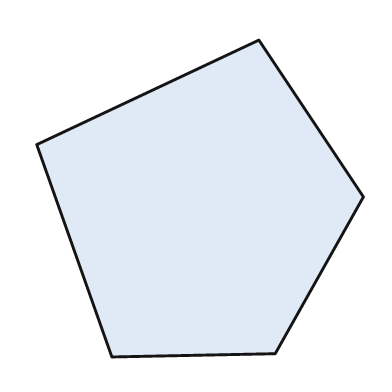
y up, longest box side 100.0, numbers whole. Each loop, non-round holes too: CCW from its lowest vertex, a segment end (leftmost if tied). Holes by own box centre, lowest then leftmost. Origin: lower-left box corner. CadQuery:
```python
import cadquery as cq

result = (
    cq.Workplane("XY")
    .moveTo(23.0, 0.0)
    .lineTo(73.0, 1.0)
    .lineTo(100.0, 49.0)
    .lineTo(68.0, 97.0)
    .lineTo(0.0, 65.0)
    .close()
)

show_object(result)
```